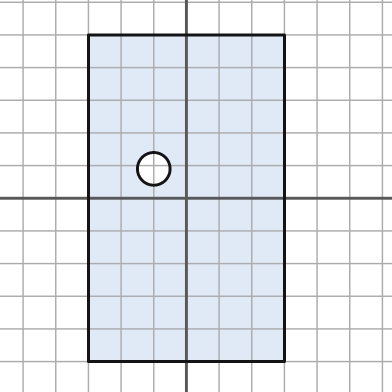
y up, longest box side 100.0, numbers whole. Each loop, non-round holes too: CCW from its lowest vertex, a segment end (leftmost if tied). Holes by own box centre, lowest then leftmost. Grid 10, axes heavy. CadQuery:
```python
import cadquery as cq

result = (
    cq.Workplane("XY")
    .moveTo(-30.0, -50.0)
    .lineTo(30.0, -50.0)
    .lineTo(30.0, 50.0)
    .lineTo(-30.0, 50.0)
    .close()
    .moveTo(-10.0, 9.0)
    .circle(5.0)
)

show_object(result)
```